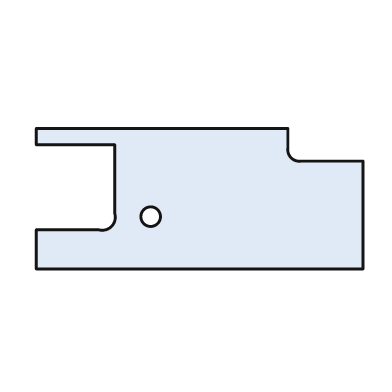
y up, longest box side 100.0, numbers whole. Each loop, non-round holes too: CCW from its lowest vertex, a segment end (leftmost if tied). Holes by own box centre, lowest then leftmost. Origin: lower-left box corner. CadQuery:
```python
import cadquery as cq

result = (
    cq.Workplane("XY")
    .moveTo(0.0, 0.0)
    .lineTo(100.0, 0.0)
    .lineTo(100.0, 33.0)
    .lineTo(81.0, 33.0)
    .threePointArc((78.0, 34.0), (77.0, 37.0))
    .lineTo(77.0, 43.0)
    .lineTo(0.0, 43.0)
    .lineTo(0.0, 38.0)
    .lineTo(24.0, 38.0)
    .lineTo(24.0, 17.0)
    .threePointArc((23.0, 13.0), (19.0, 12.0))
    .lineTo(0.0, 12.0)
    .close()
    .moveTo(35.0, 16.0)
    .circle(3.0)
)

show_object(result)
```